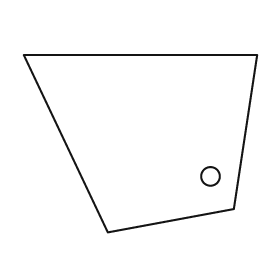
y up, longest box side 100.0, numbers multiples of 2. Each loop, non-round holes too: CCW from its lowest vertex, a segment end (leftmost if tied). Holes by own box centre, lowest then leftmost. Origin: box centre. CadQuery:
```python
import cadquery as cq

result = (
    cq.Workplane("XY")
    .moveTo(-14.0, -38.0)
    .lineTo(40.0, -28.0)
    .lineTo(50.0, 38.0)
    .lineTo(-50.0, 38.0)
    .close()
    .moveTo(30.0, -14.0)
    .circle(4.0)
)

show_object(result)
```